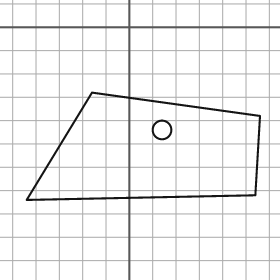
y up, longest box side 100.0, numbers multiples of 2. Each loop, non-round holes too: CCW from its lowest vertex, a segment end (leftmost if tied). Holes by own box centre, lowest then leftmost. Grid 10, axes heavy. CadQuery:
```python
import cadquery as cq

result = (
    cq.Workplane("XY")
    .moveTo(-44.0, -74.0)
    .lineTo(54.0, -72.0)
    .lineTo(56.0, -38.0)
    .lineTo(-16.0, -28.0)
    .close()
    .moveTo(14.0, -44.0)
    .circle(4.0)
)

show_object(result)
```